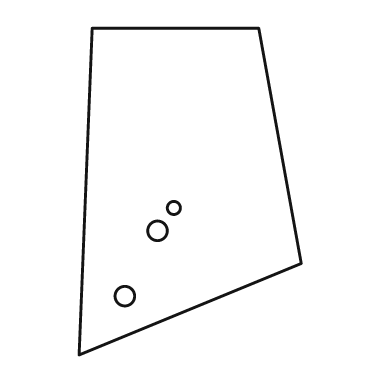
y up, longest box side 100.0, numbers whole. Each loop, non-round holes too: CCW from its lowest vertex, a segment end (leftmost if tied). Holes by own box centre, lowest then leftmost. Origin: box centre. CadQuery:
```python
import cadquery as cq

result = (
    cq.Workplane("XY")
    .moveTo(-34.0, -50.0)
    .lineTo(34.0, -22.0)
    .lineTo(21.0, 50.0)
    .lineTo(-30.0, 50.0)
    .close()
    .moveTo(-20.0, -32.0)
    .circle(3.0)
    .moveTo(-10.0, -12.0)
    .circle(3.0)
    .moveTo(-5.0, -5.0)
    .circle(2.0)
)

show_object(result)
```